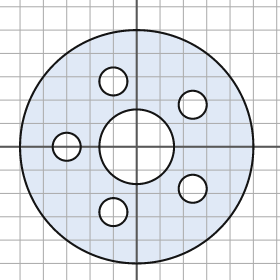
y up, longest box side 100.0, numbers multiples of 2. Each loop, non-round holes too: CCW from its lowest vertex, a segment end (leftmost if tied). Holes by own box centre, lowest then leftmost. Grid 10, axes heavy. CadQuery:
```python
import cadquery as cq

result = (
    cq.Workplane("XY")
    .moveTo(0.0, 0.0)
    .circle(50.0)
    .moveTo(-10.0, -28.0)
    .circle(6.0)
    .moveTo(24.0, -18.0)
    .circle(6.0)
    .moveTo(-30.0, 0.0)
    .circle(6.0)
    .moveTo(0.0, 0.0)
    .circle(16.0)
    .moveTo(24.0, 18.0)
    .circle(6.0)
    .moveTo(-10.0, 28.0)
    .circle(6.0)
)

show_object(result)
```